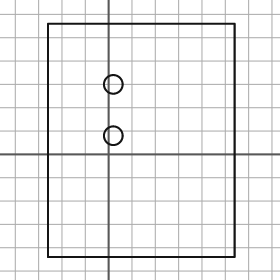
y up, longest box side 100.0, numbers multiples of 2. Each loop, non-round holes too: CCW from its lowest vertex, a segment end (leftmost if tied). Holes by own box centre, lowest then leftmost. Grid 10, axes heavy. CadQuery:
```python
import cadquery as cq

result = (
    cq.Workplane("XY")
    .moveTo(-26.0, -44.0)
    .lineTo(54.0, -44.0)
    .lineTo(54.0, 56.0)
    .lineTo(-26.0, 56.0)
    .close()
    .moveTo(2.0, 8.0)
    .circle(4.0)
    .moveTo(2.0, 30.0)
    .circle(4.0)
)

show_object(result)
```